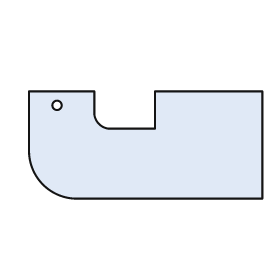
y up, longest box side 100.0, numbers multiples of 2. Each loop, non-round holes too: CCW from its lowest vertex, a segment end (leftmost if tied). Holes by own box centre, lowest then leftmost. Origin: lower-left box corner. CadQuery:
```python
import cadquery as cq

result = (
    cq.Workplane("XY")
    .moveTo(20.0, 0.0)
    .lineTo(100.0, 0.0)
    .lineTo(100.0, 46.0)
    .lineTo(54.0, 46.0)
    .lineTo(54.0, 30.0)
    .lineTo(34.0, 30.0)
    .threePointArc((30.0, 32.0), (28.0, 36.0))
    .lineTo(28.0, 46.0)
    .lineTo(0.0, 46.0)
    .lineTo(0.0, 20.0)
    .threePointArc((6.0, 6.0), (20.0, 0.0))
    .close()
    .moveTo(12.0, 40.0)
    .circle(2.0)
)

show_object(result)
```